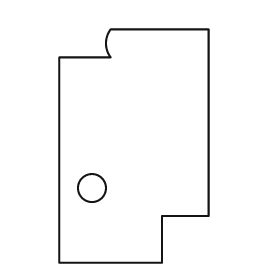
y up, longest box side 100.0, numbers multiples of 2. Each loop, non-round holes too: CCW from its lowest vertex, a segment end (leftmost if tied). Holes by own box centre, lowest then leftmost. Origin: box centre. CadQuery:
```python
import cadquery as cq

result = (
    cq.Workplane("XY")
    .moveTo(-32.0, -50.0)
    .lineTo(12.0, -50.0)
    .lineTo(12.0, -30.0)
    .lineTo(32.0, -30.0)
    .lineTo(32.0, 50.0)
    .lineTo(-10.0, 50.0)
    .threePointArc((-12.0, 44.0), (-10.0, 38.0))
    .lineTo(-32.0, 38.0)
    .close()
    .moveTo(-18.0, -18.0)
    .circle(6.0)
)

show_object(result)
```